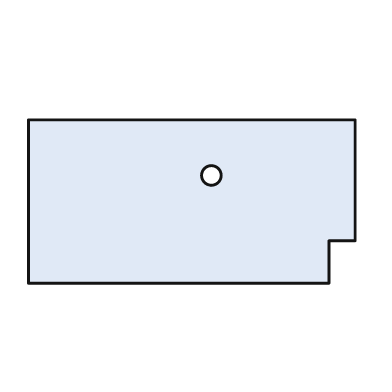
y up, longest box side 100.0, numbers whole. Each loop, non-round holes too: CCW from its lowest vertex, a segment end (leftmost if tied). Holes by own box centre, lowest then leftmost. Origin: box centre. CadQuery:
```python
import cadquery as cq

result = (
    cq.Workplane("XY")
    .moveTo(-50.0, -25.0)
    .lineTo(42.0, -25.0)
    .lineTo(42.0, -12.0)
    .lineTo(50.0, -12.0)
    .lineTo(50.0, 25.0)
    .lineTo(-50.0, 25.0)
    .close()
    .moveTo(6.0, 8.0)
    .circle(3.0)
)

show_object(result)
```